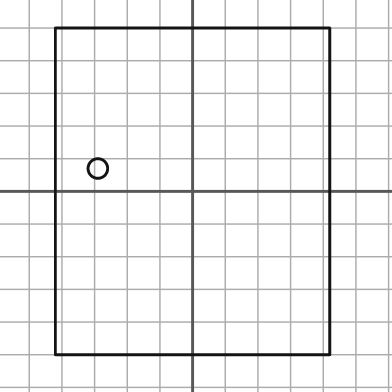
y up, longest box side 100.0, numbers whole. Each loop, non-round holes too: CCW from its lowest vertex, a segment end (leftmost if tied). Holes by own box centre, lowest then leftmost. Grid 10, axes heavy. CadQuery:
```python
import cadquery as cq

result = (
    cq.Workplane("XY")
    .moveTo(-42.0, -50.0)
    .lineTo(42.0, -50.0)
    .lineTo(42.0, 50.0)
    .lineTo(-42.0, 50.0)
    .close()
    .moveTo(-29.0, 7.0)
    .circle(3.0)
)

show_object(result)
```